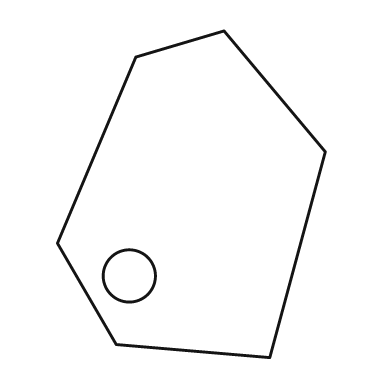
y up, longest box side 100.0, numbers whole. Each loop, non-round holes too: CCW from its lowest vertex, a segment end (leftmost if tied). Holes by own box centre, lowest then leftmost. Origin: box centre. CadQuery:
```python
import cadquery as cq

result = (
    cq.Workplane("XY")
    .moveTo(24.0, -50.0)
    .lineTo(41.0, 13.0)
    .lineTo(10.0, 50.0)
    .lineTo(-17.0, 42.0)
    .lineTo(-41.0, -15.0)
    .lineTo(-23.0, -46.0)
    .close()
    .moveTo(-19.0, -25.0)
    .circle(8.0)
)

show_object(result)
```